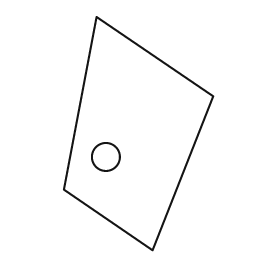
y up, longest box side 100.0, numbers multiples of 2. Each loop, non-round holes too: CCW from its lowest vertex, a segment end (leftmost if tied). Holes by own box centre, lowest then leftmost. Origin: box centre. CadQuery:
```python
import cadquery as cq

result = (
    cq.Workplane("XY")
    .moveTo(6.0, -50.0)
    .lineTo(32.0, 16.0)
    .lineTo(-18.0, 50.0)
    .lineTo(-32.0, -24.0)
    .close()
    .moveTo(-14.0, -10.0)
    .circle(6.0)
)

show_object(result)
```